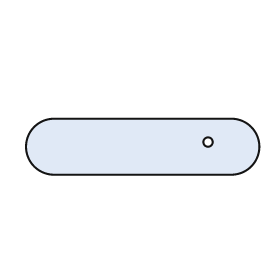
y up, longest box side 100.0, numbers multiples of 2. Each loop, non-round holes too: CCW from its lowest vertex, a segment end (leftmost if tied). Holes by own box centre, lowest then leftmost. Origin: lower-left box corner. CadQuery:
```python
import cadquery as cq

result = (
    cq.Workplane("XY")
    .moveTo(12.0, 0.0)
    .lineTo(88.0, 0.0)
    .threePointArc((100.0, 12.0), (88.0, 24.0))
    .lineTo(12.0, 24.0)
    .threePointArc((0.0, 12.0), (12.0, 0.0))
    .close()
    .moveTo(78.0, 14.0)
    .circle(2.0)
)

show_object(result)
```